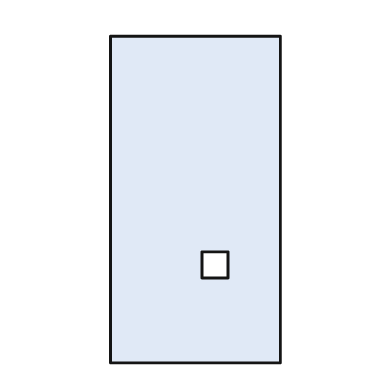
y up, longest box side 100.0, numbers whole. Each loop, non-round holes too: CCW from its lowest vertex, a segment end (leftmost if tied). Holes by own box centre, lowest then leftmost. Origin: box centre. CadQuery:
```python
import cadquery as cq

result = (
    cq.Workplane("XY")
    .moveTo(-26.0, -50.0)
    .lineTo(26.0, -50.0)
    .lineTo(26.0, 50.0)
    .lineTo(-26.0, 50.0)
    .close()
    .moveTo(2.0, -24.0)
    .lineTo(10.0, -24.0)
    .lineTo(10.0, -16.0)
    .lineTo(2.0, -16.0)
    .close()
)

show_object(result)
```